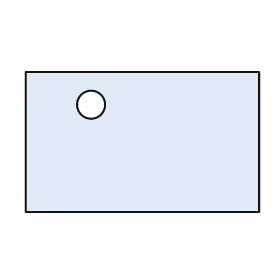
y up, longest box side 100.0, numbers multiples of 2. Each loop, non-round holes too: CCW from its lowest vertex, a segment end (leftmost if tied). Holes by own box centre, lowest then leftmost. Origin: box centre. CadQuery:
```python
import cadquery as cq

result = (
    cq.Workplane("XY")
    .moveTo(-50.0, -30.0)
    .lineTo(50.0, -30.0)
    .lineTo(50.0, 30.0)
    .lineTo(-50.0, 30.0)
    .close()
    .moveTo(-22.0, 16.0)
    .circle(6.0)
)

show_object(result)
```